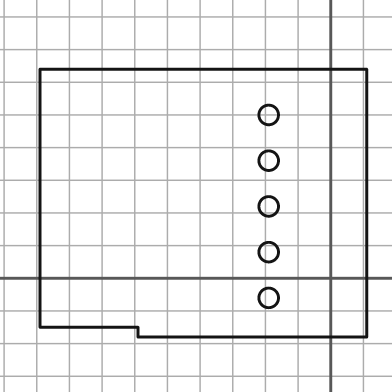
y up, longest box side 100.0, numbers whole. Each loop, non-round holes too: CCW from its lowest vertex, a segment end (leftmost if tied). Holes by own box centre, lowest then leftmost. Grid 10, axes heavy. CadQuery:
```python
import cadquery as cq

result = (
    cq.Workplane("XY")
    .moveTo(-59.0, -18.0)
    .lineTo(11.0, -18.0)
    .lineTo(11.0, 64.0)
    .lineTo(-89.0, 64.0)
    .lineTo(-89.0, -15.0)
    .lineTo(-59.0, -15.0)
    .close()
    .moveTo(-19.0, -6.0)
    .circle(3.0)
    .moveTo(-19.0, 8.0)
    .circle(3.0)
    .moveTo(-19.0, 22.0)
    .circle(3.0)
    .moveTo(-19.0, 36.0)
    .circle(3.0)
    .moveTo(-19.0, 50.0)
    .circle(3.0)
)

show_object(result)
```